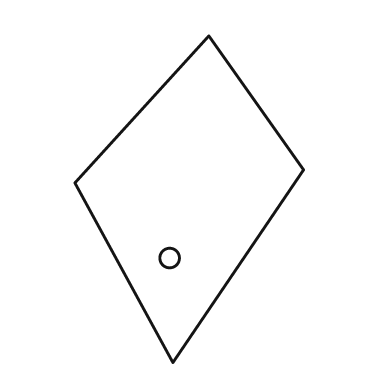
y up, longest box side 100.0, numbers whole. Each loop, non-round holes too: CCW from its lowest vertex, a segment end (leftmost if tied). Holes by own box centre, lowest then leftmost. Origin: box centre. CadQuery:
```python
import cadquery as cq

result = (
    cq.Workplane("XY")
    .moveTo(-5.0, -50.0)
    .lineTo(35.0, 9.0)
    .lineTo(6.0, 50.0)
    .lineTo(-35.0, 5.0)
    .close()
    .moveTo(-6.0, -18.0)
    .circle(3.0)
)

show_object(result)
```